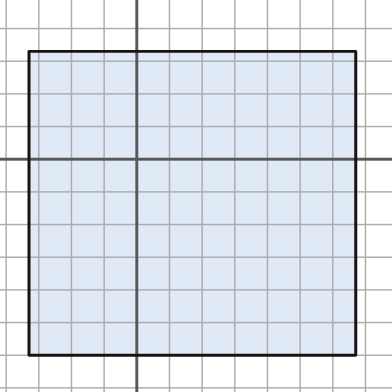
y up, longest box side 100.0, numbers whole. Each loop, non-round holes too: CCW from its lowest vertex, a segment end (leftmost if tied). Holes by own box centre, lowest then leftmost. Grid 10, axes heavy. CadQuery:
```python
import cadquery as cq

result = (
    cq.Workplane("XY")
    .moveTo(-33.0, -60.0)
    .lineTo(67.0, -60.0)
    .lineTo(67.0, 33.0)
    .lineTo(-33.0, 33.0)
    .close()
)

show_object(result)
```